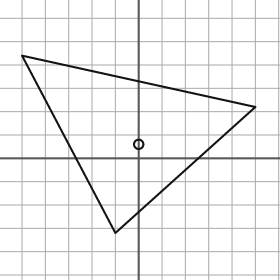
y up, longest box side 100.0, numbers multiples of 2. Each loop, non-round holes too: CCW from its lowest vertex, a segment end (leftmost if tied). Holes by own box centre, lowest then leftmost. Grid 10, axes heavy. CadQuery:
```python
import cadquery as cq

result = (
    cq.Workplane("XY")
    .moveTo(-10.0, -32.0)
    .lineTo(50.0, 22.0)
    .lineTo(-50.0, 44.0)
    .close()
    .moveTo(0.0, 6.0)
    .circle(2.0)
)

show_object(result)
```